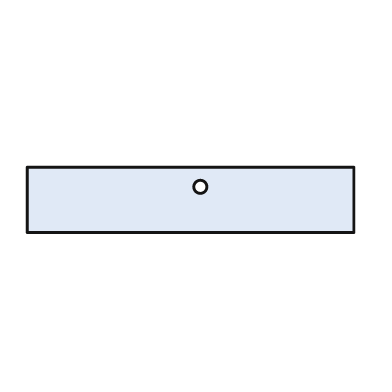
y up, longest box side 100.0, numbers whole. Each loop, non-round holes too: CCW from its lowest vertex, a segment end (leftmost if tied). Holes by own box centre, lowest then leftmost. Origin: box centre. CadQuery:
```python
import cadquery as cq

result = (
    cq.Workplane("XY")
    .moveTo(-50.0, -10.0)
    .lineTo(50.0, -10.0)
    .lineTo(50.0, 10.0)
    .lineTo(-50.0, 10.0)
    .close()
    .moveTo(3.0, 4.0)
    .circle(2.0)
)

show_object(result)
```